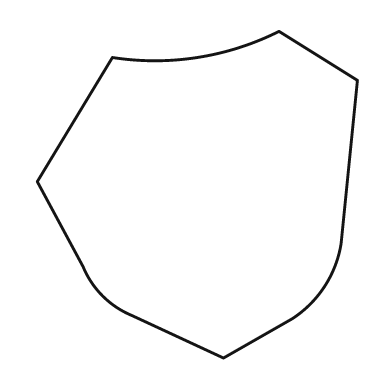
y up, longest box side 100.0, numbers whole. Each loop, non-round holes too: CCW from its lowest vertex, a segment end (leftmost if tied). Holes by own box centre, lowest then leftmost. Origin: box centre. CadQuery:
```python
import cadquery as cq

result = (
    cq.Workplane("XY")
    .moveTo(8.0, -50.0)
    .lineTo(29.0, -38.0)
    .threePointArc((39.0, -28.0), (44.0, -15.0))
    .lineTo(49.0, 35.0)
    .lineTo(25.0, 50.0)
    .threePointArc((0.0, 42.0), (-26.0, 42.0))
    .lineTo(-49.0, 4.0)
    .lineTo(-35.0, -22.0)
    .threePointArc((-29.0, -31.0), (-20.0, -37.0))
    .close()
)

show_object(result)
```